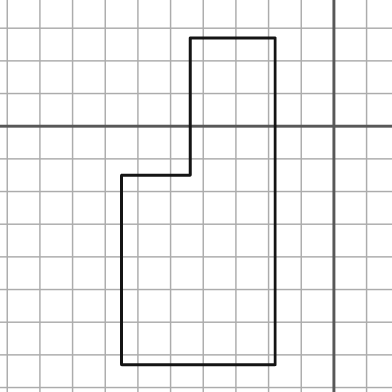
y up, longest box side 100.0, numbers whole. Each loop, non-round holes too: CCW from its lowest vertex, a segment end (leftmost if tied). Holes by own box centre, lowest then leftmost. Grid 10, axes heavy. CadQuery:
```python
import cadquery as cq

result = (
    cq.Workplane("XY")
    .moveTo(-65.0, -73.0)
    .lineTo(-18.0, -73.0)
    .lineTo(-18.0, 27.0)
    .lineTo(-44.0, 27.0)
    .lineTo(-44.0, -15.0)
    .lineTo(-65.0, -15.0)
    .close()
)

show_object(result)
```